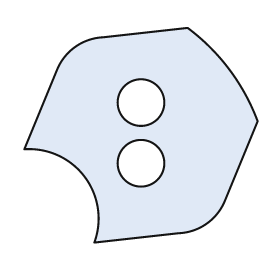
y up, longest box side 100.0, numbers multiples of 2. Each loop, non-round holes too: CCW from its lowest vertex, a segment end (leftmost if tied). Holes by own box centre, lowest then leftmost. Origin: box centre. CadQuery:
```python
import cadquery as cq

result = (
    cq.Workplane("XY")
    .moveTo(-20.0, -46.0)
    .lineTo(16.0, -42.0)
    .threePointArc((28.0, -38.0), (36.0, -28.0))
    .lineTo(50.0, 6.0)
    .threePointArc((38.0, 28.0), (20.0, 46.0))
    .lineTo(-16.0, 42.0)
    .threePointArc((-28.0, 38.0), (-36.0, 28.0))
    .lineTo(-50.0, -6.0)
    .threePointArc((-24.0, -18.0), (-20.0, -46.0))
    .close()
    .moveTo(0.0, -12.0)
    .circle(10.0)
    .moveTo(0.0, 14.0)
    .circle(10.0)
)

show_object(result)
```